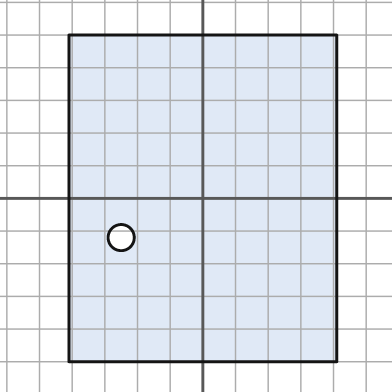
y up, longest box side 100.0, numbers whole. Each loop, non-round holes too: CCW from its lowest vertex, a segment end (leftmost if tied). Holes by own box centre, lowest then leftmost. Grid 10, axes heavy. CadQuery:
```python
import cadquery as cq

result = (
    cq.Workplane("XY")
    .moveTo(-41.0, -50.0)
    .lineTo(41.0, -50.0)
    .lineTo(41.0, 50.0)
    .lineTo(-41.0, 50.0)
    .close()
    .moveTo(-25.0, -12.0)
    .circle(4.0)
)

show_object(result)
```